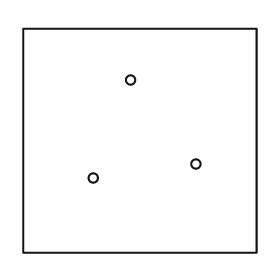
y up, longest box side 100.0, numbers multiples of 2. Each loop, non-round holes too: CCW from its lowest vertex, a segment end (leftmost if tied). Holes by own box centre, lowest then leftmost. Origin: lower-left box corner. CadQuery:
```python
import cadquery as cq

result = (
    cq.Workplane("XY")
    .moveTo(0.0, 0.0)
    .lineTo(100.0, 0.0)
    .lineTo(100.0, 96.0)
    .lineTo(0.0, 96.0)
    .close()
    .moveTo(30.0, 32.0)
    .circle(2.0)
    .moveTo(74.0, 38.0)
    .circle(2.0)
    .moveTo(46.0, 74.0)
    .circle(2.0)
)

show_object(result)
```